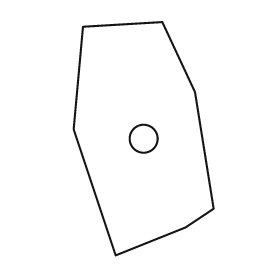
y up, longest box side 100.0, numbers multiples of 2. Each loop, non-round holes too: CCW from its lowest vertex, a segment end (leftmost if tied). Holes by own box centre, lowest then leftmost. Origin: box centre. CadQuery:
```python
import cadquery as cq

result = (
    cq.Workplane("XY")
    .moveTo(-12.0, -50.0)
    .lineTo(18.0, -38.0)
    .lineTo(30.0, -30.0)
    .lineTo(22.0, 20.0)
    .lineTo(8.0, 50.0)
    .lineTo(-26.0, 48.0)
    .lineTo(-30.0, 4.0)
    .close()
    .moveTo(0.0, 0.0)
    .circle(6.0)
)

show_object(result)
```